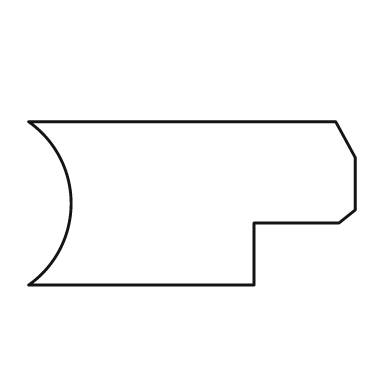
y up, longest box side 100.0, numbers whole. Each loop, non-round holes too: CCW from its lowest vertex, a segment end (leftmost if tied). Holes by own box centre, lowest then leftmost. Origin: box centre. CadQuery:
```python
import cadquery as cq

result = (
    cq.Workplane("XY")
    .moveTo(-50.0, -25.0)
    .lineTo(19.0, -25.0)
    .lineTo(19.0, -6.0)
    .lineTo(45.0, -6.0)
    .lineTo(50.0, -2.0)
    .lineTo(50.0, 14.0)
    .lineTo(44.0, 25.0)
    .lineTo(-50.0, 25.0)
    .threePointArc((-37.0, 0.0), (-50.0, -25.0))
    .close()
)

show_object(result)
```